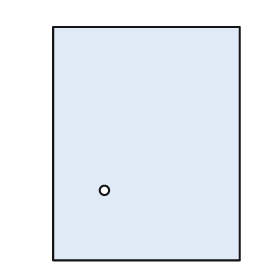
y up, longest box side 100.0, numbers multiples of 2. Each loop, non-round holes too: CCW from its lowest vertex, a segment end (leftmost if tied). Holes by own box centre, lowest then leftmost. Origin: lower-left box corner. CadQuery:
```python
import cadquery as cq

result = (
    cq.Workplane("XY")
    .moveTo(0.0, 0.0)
    .lineTo(80.0, 0.0)
    .lineTo(80.0, 100.0)
    .lineTo(0.0, 100.0)
    .close()
    .moveTo(22.0, 30.0)
    .circle(2.0)
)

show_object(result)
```